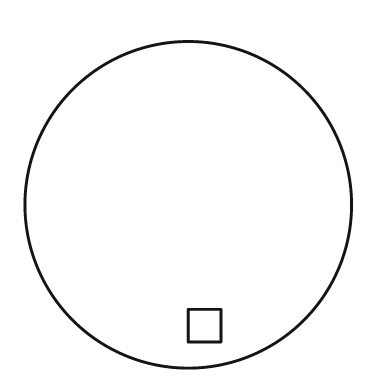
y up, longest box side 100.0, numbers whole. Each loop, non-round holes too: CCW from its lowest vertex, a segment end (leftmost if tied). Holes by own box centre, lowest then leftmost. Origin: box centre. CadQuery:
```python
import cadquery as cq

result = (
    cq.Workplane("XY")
    .moveTo(0.0, 0.0)
    .circle(50.0)
    .moveTo(0.0, -42.0)
    .lineTo(10.0, -42.0)
    .lineTo(10.0, -32.0)
    .lineTo(0.0, -32.0)
    .close()
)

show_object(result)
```